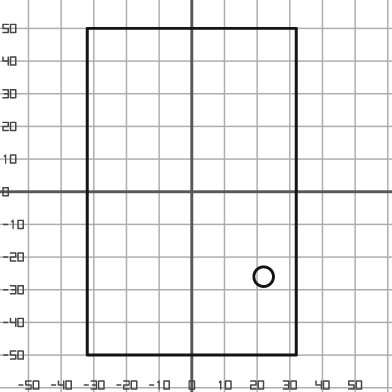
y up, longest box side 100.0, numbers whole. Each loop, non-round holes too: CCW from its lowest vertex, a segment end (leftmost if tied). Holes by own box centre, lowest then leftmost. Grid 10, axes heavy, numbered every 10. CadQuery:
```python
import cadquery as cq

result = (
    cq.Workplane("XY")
    .moveTo(-32.0, -50.0)
    .lineTo(32.0, -50.0)
    .lineTo(32.0, 50.0)
    .lineTo(-32.0, 50.0)
    .close()
    .moveTo(22.0, -26.0)
    .circle(3.0)
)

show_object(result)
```